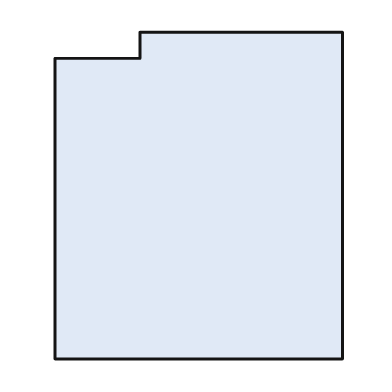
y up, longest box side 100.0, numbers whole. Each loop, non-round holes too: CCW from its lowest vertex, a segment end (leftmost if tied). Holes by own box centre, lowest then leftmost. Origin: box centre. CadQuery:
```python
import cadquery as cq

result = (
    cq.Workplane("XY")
    .moveTo(-44.0, -50.0)
    .lineTo(44.0, -50.0)
    .lineTo(44.0, 50.0)
    .lineTo(-18.0, 50.0)
    .lineTo(-18.0, 42.0)
    .lineTo(-44.0, 42.0)
    .close()
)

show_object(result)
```